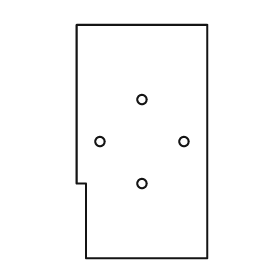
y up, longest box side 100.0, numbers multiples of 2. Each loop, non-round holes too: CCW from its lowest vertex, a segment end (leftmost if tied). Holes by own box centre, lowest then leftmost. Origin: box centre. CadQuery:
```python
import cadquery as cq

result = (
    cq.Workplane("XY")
    .moveTo(-24.0, -50.0)
    .lineTo(28.0, -50.0)
    .lineTo(28.0, 50.0)
    .lineTo(-28.0, 50.0)
    .lineTo(-28.0, -18.0)
    .lineTo(-24.0, -18.0)
    .close()
    .moveTo(0.0, -18.0)
    .circle(2.0)
    .moveTo(-18.0, 0.0)
    .circle(2.0)
    .moveTo(18.0, 0.0)
    .circle(2.0)
    .moveTo(0.0, 18.0)
    .circle(2.0)
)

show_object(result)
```